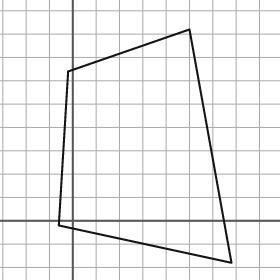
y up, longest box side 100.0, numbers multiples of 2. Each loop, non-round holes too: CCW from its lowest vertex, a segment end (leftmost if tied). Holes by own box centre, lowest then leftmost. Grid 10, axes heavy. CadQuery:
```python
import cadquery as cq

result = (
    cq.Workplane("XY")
    .moveTo(68.0, -18.0)
    .lineTo(50.0, 82.0)
    .lineTo(-2.0, 64.0)
    .lineTo(-6.0, -2.0)
    .close()
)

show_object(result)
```